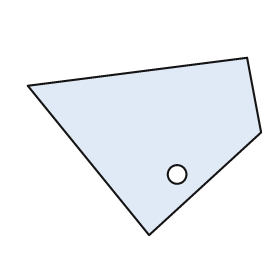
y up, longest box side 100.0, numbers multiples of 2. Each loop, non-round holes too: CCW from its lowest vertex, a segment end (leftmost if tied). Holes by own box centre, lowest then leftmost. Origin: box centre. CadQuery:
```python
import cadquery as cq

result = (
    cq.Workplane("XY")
    .moveTo(2.0, -38.0)
    .lineTo(50.0, 6.0)
    .lineTo(44.0, 38.0)
    .lineTo(-50.0, 26.0)
    .close()
    .moveTo(14.0, -12.0)
    .circle(4.0)
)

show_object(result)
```